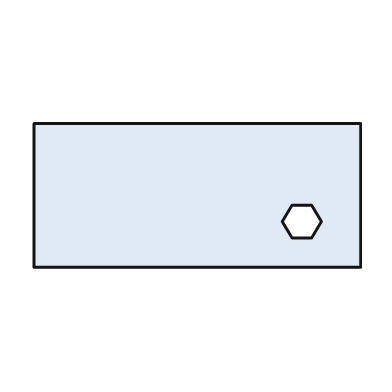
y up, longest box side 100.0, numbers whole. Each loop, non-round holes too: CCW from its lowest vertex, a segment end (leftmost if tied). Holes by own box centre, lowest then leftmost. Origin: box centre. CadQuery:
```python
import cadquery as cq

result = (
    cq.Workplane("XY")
    .moveTo(-50.0, -22.0)
    .lineTo(50.0, -22.0)
    .lineTo(50.0, 22.0)
    .lineTo(-50.0, 22.0)
    .close()
    .moveTo(29.0, -13.0)
    .lineTo(35.0, -13.0)
    .lineTo(38.0, -8.0)
    .lineTo(35.0, -3.0)
    .lineTo(29.0, -3.0)
    .lineTo(26.0, -8.0)
    .close()
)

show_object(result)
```